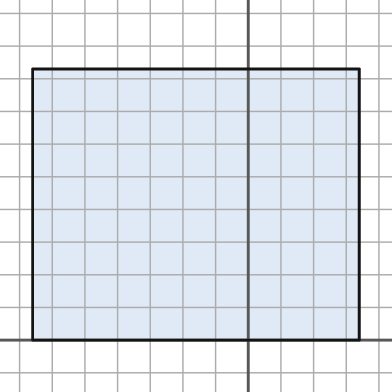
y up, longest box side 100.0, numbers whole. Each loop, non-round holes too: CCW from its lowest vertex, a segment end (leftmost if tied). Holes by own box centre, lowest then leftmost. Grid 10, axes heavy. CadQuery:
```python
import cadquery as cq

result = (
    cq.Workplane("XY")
    .moveTo(-66.0, 0.0)
    .lineTo(34.0, 0.0)
    .lineTo(34.0, 83.0)
    .lineTo(-66.0, 83.0)
    .close()
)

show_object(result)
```